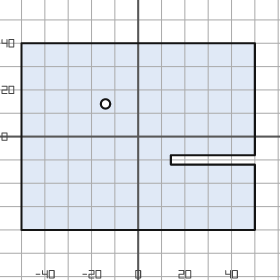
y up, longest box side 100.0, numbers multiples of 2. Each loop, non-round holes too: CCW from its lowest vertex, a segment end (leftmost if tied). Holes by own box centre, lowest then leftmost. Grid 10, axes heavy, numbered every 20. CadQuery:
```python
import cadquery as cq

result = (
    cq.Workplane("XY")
    .moveTo(-50.0, -40.0)
    .lineTo(50.0, -40.0)
    .lineTo(50.0, -12.0)
    .lineTo(14.0, -12.0)
    .lineTo(14.0, -8.0)
    .lineTo(50.0, -8.0)
    .lineTo(50.0, 40.0)
    .lineTo(-50.0, 40.0)
    .close()
    .moveTo(-14.0, 14.0)
    .circle(2.0)
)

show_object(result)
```